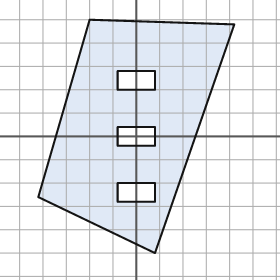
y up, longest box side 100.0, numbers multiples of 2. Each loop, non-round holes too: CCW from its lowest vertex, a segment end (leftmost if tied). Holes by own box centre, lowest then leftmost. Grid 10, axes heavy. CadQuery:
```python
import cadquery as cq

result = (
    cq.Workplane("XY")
    .moveTo(8.0, -50.0)
    .lineTo(42.0, 48.0)
    .lineTo(-20.0, 50.0)
    .lineTo(-42.0, -26.0)
    .close()
    .moveTo(-8.0, -28.0)
    .lineTo(8.0, -28.0)
    .lineTo(8.0, -20.0)
    .lineTo(-8.0, -20.0)
    .close()
    .moveTo(-8.0, -4.0)
    .lineTo(8.0, -4.0)
    .lineTo(8.0, 4.0)
    .lineTo(-8.0, 4.0)
    .close()
    .moveTo(-8.0, 20.0)
    .lineTo(8.0, 20.0)
    .lineTo(8.0, 28.0)
    .lineTo(-8.0, 28.0)
    .close()
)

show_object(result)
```